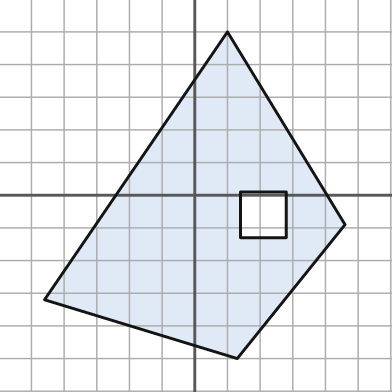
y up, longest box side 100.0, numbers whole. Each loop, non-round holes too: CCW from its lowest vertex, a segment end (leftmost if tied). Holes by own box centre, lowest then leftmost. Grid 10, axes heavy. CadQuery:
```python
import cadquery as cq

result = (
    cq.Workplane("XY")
    .moveTo(13.0, -50.0)
    .lineTo(46.0, -9.0)
    .lineTo(10.0, 50.0)
    .lineTo(-46.0, -32.0)
    .close()
    .moveTo(14.0, -13.0)
    .lineTo(28.0, -13.0)
    .lineTo(28.0, 1.0)
    .lineTo(14.0, 1.0)
    .close()
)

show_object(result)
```